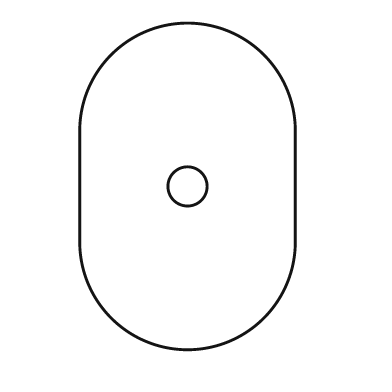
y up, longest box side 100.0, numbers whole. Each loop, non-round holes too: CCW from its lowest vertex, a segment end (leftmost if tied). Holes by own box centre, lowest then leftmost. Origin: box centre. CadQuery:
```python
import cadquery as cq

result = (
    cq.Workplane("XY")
    .moveTo(-33.0, -17.0)
    .threePointArc((0.0, -50.0), (33.0, -17.0))
    .lineTo(33.0, 17.0)
    .threePointArc((0.0, 50.0), (-33.0, 17.0))
    .close()
    .moveTo(0.0, 0.0)
    .circle(6.0)
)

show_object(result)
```